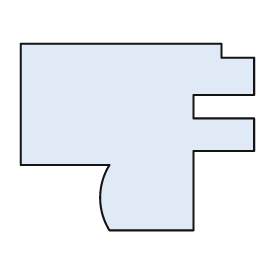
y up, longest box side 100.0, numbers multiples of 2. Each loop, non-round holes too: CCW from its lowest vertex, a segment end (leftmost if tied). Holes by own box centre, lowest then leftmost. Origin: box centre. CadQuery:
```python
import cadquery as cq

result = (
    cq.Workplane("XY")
    .moveTo(-12.0, -40.0)
    .lineTo(24.0, -40.0)
    .lineTo(24.0, -6.0)
    .lineTo(50.0, -6.0)
    .lineTo(50.0, 8.0)
    .lineTo(24.0, 8.0)
    .lineTo(24.0, 18.0)
    .lineTo(50.0, 18.0)
    .lineTo(50.0, 34.0)
    .lineTo(36.0, 34.0)
    .lineTo(36.0, 40.0)
    .lineTo(-50.0, 40.0)
    .lineTo(-50.0, -12.0)
    .lineTo(-12.0, -12.0)
    .threePointArc((-16.0, -26.0), (-12.0, -40.0))
    .close()
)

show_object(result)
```